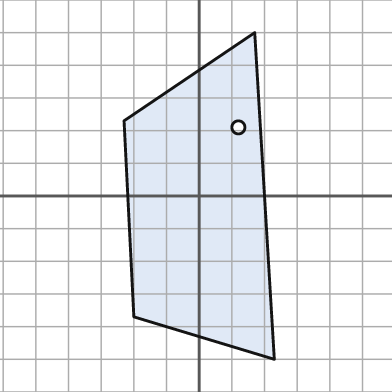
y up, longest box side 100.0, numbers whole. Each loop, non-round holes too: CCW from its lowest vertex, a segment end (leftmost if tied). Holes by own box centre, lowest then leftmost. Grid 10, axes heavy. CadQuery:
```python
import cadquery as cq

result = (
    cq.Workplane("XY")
    .moveTo(23.0, -50.0)
    .lineTo(17.0, 50.0)
    .lineTo(-23.0, 23.0)
    .lineTo(-20.0, -37.0)
    .close()
    .moveTo(12.0, 21.0)
    .circle(2.0)
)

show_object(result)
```